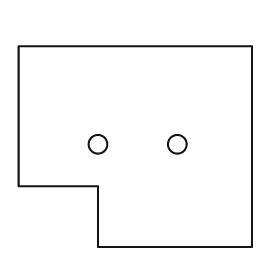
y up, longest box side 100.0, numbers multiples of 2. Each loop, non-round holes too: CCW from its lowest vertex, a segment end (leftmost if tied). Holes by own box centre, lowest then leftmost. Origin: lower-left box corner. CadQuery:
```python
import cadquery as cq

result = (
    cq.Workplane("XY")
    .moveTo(34.0, 0.0)
    .lineTo(100.0, 0.0)
    .lineTo(100.0, 86.0)
    .lineTo(0.0, 86.0)
    .lineTo(0.0, 26.0)
    .lineTo(34.0, 26.0)
    .close()
    .moveTo(34.0, 44.0)
    .circle(4.0)
    .moveTo(68.0, 44.0)
    .circle(4.0)
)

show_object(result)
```